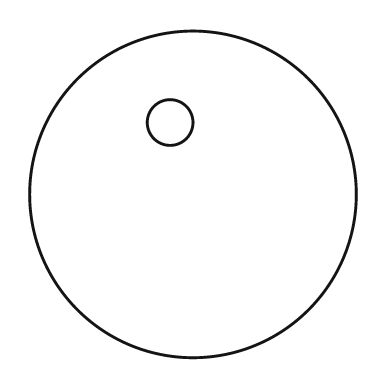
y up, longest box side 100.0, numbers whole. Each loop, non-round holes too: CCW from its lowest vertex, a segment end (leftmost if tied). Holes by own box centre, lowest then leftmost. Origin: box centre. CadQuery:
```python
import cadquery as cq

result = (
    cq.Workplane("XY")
    .moveTo(0.0, 0.0)
    .circle(50.0)
    .moveTo(-7.0, 22.0)
    .circle(7.0)
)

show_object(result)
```